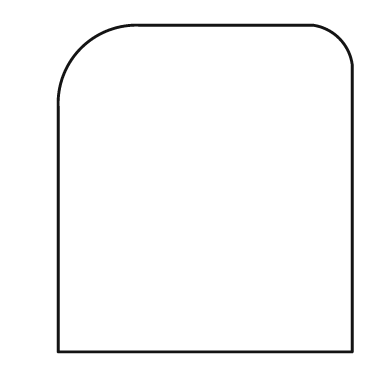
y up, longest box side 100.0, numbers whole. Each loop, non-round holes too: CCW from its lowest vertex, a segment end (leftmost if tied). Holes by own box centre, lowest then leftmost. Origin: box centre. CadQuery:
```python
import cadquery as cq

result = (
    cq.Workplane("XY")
    .moveTo(-45.0, -50.0)
    .lineTo(45.0, -50.0)
    .lineTo(45.0, 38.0)
    .threePointArc((41.0, 46.0), (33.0, 50.0))
    .lineTo(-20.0, 50.0)
    .threePointArc((-38.0, 43.0), (-45.0, 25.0))
    .close()
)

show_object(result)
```